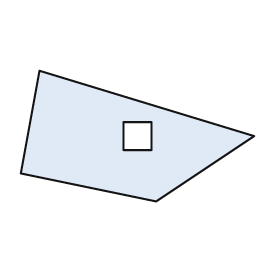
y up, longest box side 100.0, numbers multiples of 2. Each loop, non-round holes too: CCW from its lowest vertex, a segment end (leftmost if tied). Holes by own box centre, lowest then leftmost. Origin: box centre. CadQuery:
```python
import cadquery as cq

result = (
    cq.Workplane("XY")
    .moveTo(8.0, -28.0)
    .lineTo(50.0, 0.0)
    .lineTo(-42.0, 28.0)
    .lineTo(-50.0, -16.0)
    .close()
    .moveTo(-6.0, -6.0)
    .lineTo(6.0, -6.0)
    .lineTo(6.0, 6.0)
    .lineTo(-6.0, 6.0)
    .close()
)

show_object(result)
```